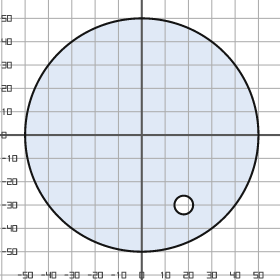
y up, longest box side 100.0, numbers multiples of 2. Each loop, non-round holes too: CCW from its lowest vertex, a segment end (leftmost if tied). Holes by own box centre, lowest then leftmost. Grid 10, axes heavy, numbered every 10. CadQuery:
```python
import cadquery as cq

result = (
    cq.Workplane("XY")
    .moveTo(0.0, 0.0)
    .circle(50.0)
    .moveTo(18.0, -30.0)
    .circle(4.0)
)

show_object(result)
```